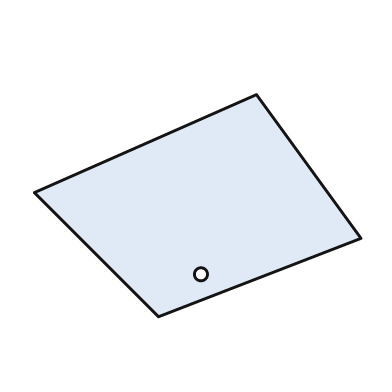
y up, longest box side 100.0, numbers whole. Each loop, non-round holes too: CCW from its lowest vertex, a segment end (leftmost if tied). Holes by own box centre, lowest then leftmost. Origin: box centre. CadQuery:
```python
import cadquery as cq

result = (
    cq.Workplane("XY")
    .moveTo(-12.0, -34.0)
    .lineTo(50.0, -10.0)
    .lineTo(18.0, 34.0)
    .lineTo(-50.0, 4.0)
    .close()
    .moveTo(1.0, -21.0)
    .circle(2.0)
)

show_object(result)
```